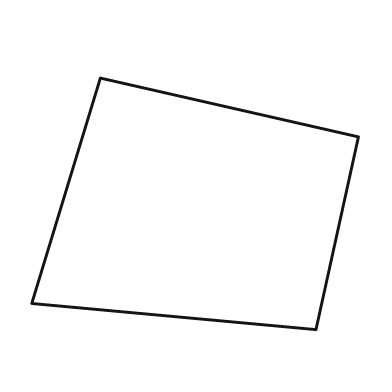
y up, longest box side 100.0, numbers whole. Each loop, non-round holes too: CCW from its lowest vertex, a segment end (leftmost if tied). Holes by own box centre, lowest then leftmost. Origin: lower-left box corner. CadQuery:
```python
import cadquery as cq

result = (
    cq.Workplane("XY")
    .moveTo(87.0, 0.0)
    .lineTo(100.0, 59.0)
    .lineTo(21.0, 77.0)
    .lineTo(0.0, 8.0)
    .close()
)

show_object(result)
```